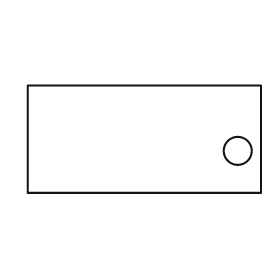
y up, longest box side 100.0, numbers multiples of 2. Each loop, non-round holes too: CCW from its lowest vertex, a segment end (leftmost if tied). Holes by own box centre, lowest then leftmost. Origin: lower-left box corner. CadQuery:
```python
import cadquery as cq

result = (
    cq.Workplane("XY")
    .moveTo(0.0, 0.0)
    .lineTo(100.0, 0.0)
    .lineTo(100.0, 46.0)
    .lineTo(0.0, 46.0)
    .close()
    .moveTo(90.0, 18.0)
    .circle(6.0)
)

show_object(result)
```